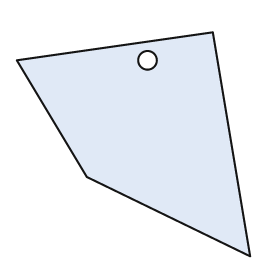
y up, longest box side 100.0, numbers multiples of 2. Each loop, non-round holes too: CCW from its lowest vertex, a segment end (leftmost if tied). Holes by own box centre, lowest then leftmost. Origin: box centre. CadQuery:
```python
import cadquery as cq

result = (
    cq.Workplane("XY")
    .moveTo(50.0, -48.0)
    .lineTo(34.0, 48.0)
    .lineTo(-50.0, 36.0)
    .lineTo(-20.0, -14.0)
    .close()
    .moveTo(6.0, 36.0)
    .circle(4.0)
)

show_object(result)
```